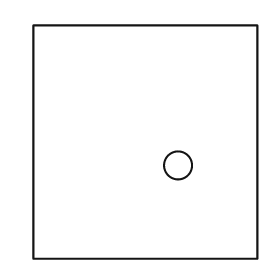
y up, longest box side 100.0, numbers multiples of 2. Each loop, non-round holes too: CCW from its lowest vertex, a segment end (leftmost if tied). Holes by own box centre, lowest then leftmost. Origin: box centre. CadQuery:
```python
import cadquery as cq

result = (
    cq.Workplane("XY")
    .moveTo(-48.0, -50.0)
    .lineTo(48.0, -50.0)
    .lineTo(48.0, 50.0)
    .lineTo(-48.0, 50.0)
    .close()
    .moveTo(14.0, -10.0)
    .circle(6.0)
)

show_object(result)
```